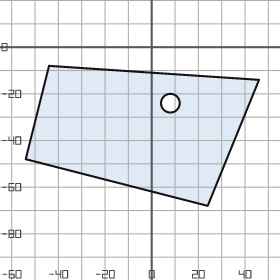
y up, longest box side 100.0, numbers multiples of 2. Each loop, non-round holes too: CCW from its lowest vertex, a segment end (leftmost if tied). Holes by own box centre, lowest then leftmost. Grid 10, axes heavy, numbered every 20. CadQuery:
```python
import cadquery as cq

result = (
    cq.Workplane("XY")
    .moveTo(24.0, -68.0)
    .lineTo(46.0, -14.0)
    .lineTo(-44.0, -8.0)
    .lineTo(-54.0, -48.0)
    .close()
    .moveTo(8.0, -24.0)
    .circle(4.0)
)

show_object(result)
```